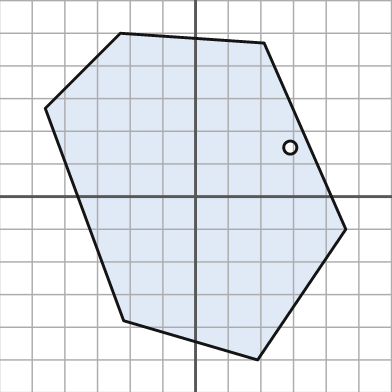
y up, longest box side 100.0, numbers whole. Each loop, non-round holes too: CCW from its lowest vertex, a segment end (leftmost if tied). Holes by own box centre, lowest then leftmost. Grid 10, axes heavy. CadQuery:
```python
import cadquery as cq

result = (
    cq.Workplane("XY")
    .moveTo(19.0, -50.0)
    .lineTo(46.0, -10.0)
    .lineTo(21.0, 47.0)
    .lineTo(-23.0, 50.0)
    .lineTo(-46.0, 27.0)
    .lineTo(-22.0, -38.0)
    .close()
    .moveTo(29.0, 15.0)
    .circle(2.0)
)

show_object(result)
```